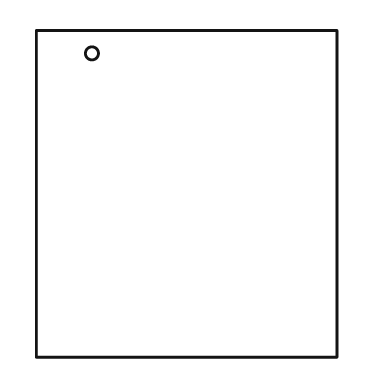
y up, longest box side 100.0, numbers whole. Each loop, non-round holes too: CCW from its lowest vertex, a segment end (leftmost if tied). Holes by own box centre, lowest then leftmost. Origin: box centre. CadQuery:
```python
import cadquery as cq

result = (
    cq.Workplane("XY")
    .moveTo(-46.0, -50.0)
    .lineTo(46.0, -50.0)
    .lineTo(46.0, 50.0)
    .lineTo(-46.0, 50.0)
    .close()
    .moveTo(-29.0, 43.0)
    .circle(2.0)
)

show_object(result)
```